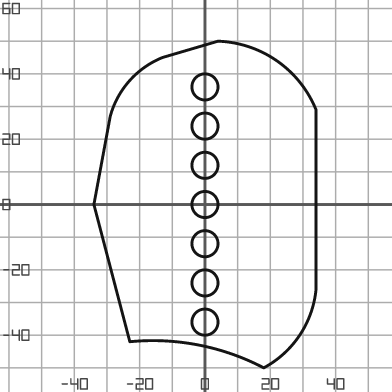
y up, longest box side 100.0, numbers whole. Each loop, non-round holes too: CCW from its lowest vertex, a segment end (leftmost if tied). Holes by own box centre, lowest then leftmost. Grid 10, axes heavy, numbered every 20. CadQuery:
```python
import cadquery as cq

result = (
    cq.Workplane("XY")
    .moveTo(18.0, -50.0)
    .threePointArc((29.0, -40.0), (34.0, -26.0))
    .lineTo(34.0, 29.0)
    .threePointArc((22.0, 44.0), (4.0, 50.0))
    .lineTo(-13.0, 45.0)
    .threePointArc((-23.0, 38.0), (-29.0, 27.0))
    .lineTo(-34.0, 0.0)
    .lineTo(-23.0, -42.0)
    .threePointArc((-2.0, -43.0), (18.0, -50.0))
    .close()
    .moveTo(0.0, -36.0)
    .circle(4.0)
    .moveTo(0.0, -24.0)
    .circle(4.0)
    .moveTo(0.0, -12.0)
    .circle(4.0)
    .moveTo(0.0, 0.0)
    .circle(4.0)
    .moveTo(0.0, 12.0)
    .circle(4.0)
    .moveTo(0.0, 24.0)
    .circle(4.0)
    .moveTo(0.0, 36.0)
    .circle(4.0)
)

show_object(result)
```